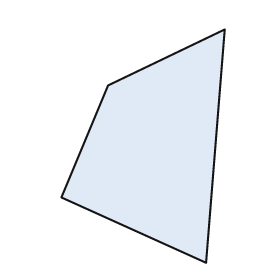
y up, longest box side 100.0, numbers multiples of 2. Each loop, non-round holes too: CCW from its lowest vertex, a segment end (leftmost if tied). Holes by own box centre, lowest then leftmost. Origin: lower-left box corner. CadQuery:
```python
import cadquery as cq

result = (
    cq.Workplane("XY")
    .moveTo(62.0, 0.0)
    .lineTo(70.0, 100.0)
    .lineTo(20.0, 76.0)
    .lineTo(0.0, 28.0)
    .close()
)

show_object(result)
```